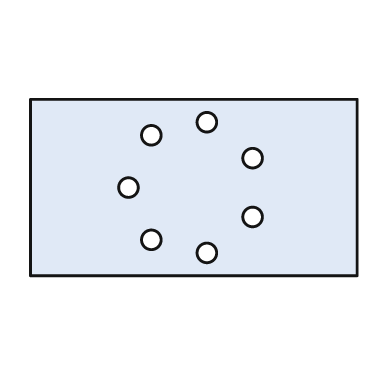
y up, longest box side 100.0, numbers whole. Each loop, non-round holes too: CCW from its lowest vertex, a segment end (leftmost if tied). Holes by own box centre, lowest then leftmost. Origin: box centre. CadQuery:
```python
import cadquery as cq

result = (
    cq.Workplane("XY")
    .moveTo(-50.0, -27.0)
    .lineTo(50.0, -27.0)
    .lineTo(50.0, 27.0)
    .lineTo(-50.0, 27.0)
    .close()
    .moveTo(4.0, -20.0)
    .circle(3.0)
    .moveTo(-13.0, -16.0)
    .circle(3.0)
    .moveTo(18.0, -9.0)
    .circle(3.0)
    .moveTo(-20.0, 0.0)
    .circle(3.0)
    .moveTo(18.0, 9.0)
    .circle(3.0)
    .moveTo(-13.0, 16.0)
    .circle(3.0)
    .moveTo(4.0, 20.0)
    .circle(3.0)
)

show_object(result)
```